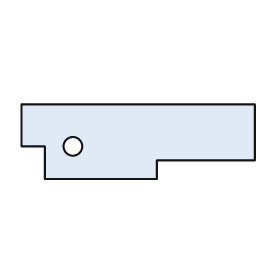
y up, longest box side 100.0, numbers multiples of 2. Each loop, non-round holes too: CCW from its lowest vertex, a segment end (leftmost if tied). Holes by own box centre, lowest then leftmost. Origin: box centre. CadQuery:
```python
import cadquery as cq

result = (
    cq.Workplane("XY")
    .moveTo(-40.0, -16.0)
    .lineTo(8.0, -16.0)
    .lineTo(8.0, -8.0)
    .lineTo(50.0, -8.0)
    .lineTo(50.0, 16.0)
    .lineTo(-50.0, 16.0)
    .lineTo(-50.0, -2.0)
    .lineTo(-40.0, -2.0)
    .close()
    .moveTo(-28.0, -2.0)
    .circle(4.0)
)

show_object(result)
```